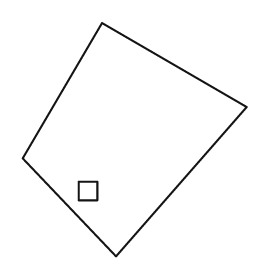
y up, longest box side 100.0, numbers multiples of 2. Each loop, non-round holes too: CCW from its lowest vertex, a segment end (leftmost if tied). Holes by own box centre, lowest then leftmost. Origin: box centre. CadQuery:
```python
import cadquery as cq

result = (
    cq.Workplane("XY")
    .moveTo(-8.0, -50.0)
    .lineTo(48.0, 14.0)
    .lineTo(-14.0, 50.0)
    .lineTo(-48.0, -8.0)
    .close()
    .moveTo(-24.0, -26.0)
    .lineTo(-16.0, -26.0)
    .lineTo(-16.0, -18.0)
    .lineTo(-24.0, -18.0)
    .close()
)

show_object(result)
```